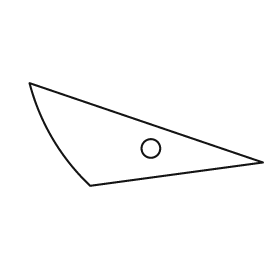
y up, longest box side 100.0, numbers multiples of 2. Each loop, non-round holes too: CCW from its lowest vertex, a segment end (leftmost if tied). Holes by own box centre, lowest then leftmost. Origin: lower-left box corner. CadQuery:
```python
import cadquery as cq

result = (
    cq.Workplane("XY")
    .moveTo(26.0, 0.0)
    .lineTo(100.0, 10.0)
    .lineTo(0.0, 44.0)
    .threePointArc((10.0, 20.0), (26.0, 0.0))
    .close()
    .moveTo(52.0, 16.0)
    .circle(4.0)
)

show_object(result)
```